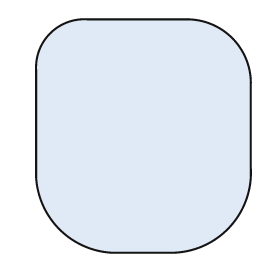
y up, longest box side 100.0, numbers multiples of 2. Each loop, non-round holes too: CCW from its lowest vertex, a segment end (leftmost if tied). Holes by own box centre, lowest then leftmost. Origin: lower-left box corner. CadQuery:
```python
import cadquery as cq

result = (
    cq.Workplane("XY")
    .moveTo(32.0, 0.0)
    .lineTo(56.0, 0.0)
    .threePointArc((82.0, 10.0), (92.0, 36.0))
    .lineTo(92.0, 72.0)
    .threePointArc((84.0, 92.0), (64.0, 100.0))
    .lineTo(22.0, 100.0)
    .threePointArc((6.0, 94.0), (0.0, 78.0))
    .lineTo(0.0, 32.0)
    .threePointArc((10.0, 10.0), (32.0, 0.0))
    .close()
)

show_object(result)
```